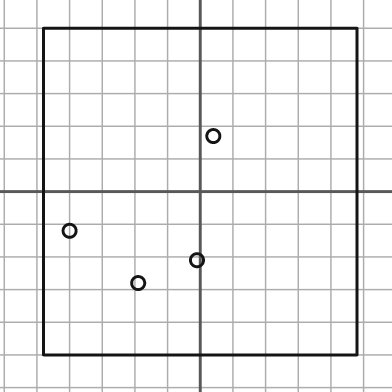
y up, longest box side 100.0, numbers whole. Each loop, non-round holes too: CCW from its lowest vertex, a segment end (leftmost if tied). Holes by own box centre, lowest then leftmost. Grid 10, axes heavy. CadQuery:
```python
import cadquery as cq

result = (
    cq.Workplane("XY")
    .moveTo(-48.0, -50.0)
    .lineTo(48.0, -50.0)
    .lineTo(48.0, 50.0)
    .lineTo(-48.0, 50.0)
    .close()
    .moveTo(-19.0, -28.0)
    .circle(2.0)
    .moveTo(-1.0, -21.0)
    .circle(2.0)
    .moveTo(-40.0, -12.0)
    .circle(2.0)
    .moveTo(4.0, 17.0)
    .circle(2.0)
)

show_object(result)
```